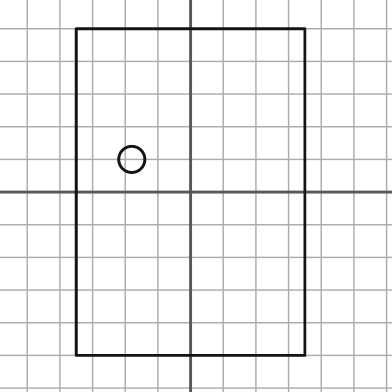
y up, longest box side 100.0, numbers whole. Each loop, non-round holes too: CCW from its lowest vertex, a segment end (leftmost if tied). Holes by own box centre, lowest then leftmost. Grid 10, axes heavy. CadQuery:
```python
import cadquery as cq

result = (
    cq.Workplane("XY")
    .moveTo(-35.0, -50.0)
    .lineTo(35.0, -50.0)
    .lineTo(35.0, 50.0)
    .lineTo(-35.0, 50.0)
    .close()
    .moveTo(-18.0, 10.0)
    .circle(4.0)
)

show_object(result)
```